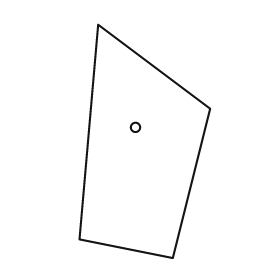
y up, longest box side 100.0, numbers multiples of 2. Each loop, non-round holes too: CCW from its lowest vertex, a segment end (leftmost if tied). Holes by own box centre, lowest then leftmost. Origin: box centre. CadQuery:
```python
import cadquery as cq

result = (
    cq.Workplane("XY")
    .moveTo(12.0, -50.0)
    .lineTo(28.0, 14.0)
    .lineTo(-20.0, 50.0)
    .lineTo(-28.0, -42.0)
    .close()
    .moveTo(-4.0, 6.0)
    .circle(2.0)
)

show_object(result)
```